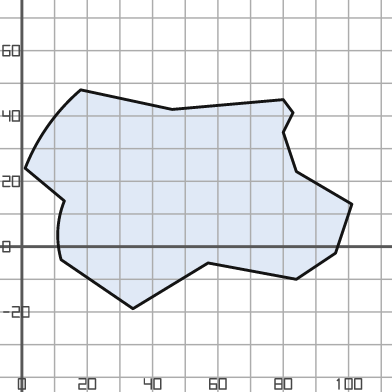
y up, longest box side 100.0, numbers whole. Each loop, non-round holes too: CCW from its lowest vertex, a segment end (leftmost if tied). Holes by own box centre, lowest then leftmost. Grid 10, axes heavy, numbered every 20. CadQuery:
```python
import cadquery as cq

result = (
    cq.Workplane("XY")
    .moveTo(34.0, -19.0)
    .lineTo(57.0, -5.0)
    .lineTo(84.0, -10.0)
    .lineTo(96.0, -2.0)
    .lineTo(101.0, 13.0)
    .lineTo(84.0, 23.0)
    .lineTo(80.0, 35.0)
    .lineTo(83.0, 41.0)
    .lineTo(80.0, 45.0)
    .lineTo(46.0, 42.0)
    .lineTo(18.0, 48.0)
    .threePointArc((8.0, 37.0), (1.0, 24.0))
    .lineTo(13.0, 14.0)
    .threePointArc((11.0, 5.0), (12.0, -4.0))
    .close()
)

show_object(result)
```